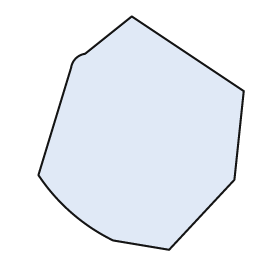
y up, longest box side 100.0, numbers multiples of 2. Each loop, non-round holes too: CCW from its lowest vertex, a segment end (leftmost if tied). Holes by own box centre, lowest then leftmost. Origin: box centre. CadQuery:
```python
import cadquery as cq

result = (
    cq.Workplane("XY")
    .moveTo(12.0, -50.0)
    .lineTo(40.0, -20.0)
    .lineTo(44.0, 18.0)
    .lineTo(-4.0, 50.0)
    .lineTo(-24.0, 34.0)
    .threePointArc((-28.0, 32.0), (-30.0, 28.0))
    .lineTo(-44.0, -18.0)
    .threePointArc((-30.0, -34.0), (-12.0, -46.0))
    .close()
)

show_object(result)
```